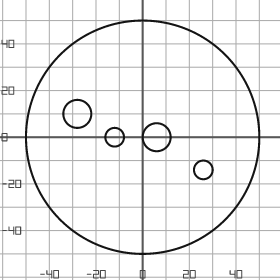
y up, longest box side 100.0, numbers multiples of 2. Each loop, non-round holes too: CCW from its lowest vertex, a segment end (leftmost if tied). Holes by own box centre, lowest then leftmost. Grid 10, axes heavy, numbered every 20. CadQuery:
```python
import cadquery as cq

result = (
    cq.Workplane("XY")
    .moveTo(0.0, 0.0)
    .circle(50.0)
    .moveTo(26.0, -14.0)
    .circle(4.0)
    .moveTo(-12.0, 0.0)
    .circle(4.0)
    .moveTo(6.0, 0.0)
    .circle(6.0)
    .moveTo(-28.0, 10.0)
    .circle(6.0)
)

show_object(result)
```